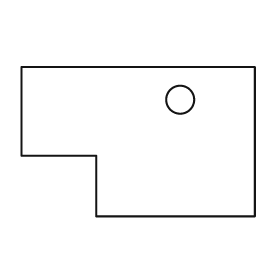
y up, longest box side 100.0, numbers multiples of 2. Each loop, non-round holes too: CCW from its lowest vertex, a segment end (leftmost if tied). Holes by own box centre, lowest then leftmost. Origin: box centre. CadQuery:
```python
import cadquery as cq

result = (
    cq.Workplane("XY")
    .moveTo(-18.0, -32.0)
    .lineTo(50.0, -32.0)
    .lineTo(50.0, 32.0)
    .lineTo(-50.0, 32.0)
    .lineTo(-50.0, -6.0)
    .lineTo(-18.0, -6.0)
    .close()
    .moveTo(18.0, 18.0)
    .circle(6.0)
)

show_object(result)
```